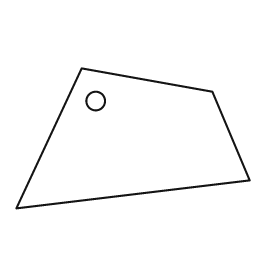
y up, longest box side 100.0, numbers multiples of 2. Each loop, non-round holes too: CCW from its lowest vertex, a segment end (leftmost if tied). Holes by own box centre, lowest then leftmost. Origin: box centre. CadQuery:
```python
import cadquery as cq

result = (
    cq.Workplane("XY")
    .moveTo(-50.0, -30.0)
    .lineTo(50.0, -18.0)
    .lineTo(34.0, 20.0)
    .lineTo(-22.0, 30.0)
    .close()
    .moveTo(-16.0, 16.0)
    .circle(4.0)
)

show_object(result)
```